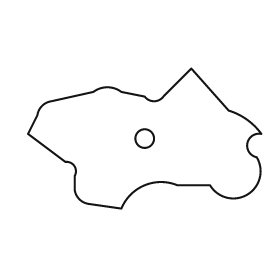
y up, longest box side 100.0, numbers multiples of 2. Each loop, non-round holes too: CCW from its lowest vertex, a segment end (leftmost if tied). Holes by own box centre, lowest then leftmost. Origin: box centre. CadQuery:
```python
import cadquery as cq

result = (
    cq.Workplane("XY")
    .moveTo(-10.0, -30.0)
    .threePointArc((0.0, -20.0), (14.0, -20.0))
    .lineTo(28.0, -20.0)
    .threePointArc((44.0, -24.0), (48.0, -8.0))
    .threePointArc((44.0, -2.0), (50.0, 2.0))
    .threePointArc((44.0, 8.0), (36.0, 12.0))
    .lineTo(20.0, 30.0)
    .lineTo(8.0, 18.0)
    .threePointArc((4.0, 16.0), (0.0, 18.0))
    .lineTo(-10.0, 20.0)
    .threePointArc((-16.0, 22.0), (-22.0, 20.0))
    .lineTo(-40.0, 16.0)
    .threePointArc((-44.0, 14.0), (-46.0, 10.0))
    .lineTo(-50.0, 2.0)
    .lineTo(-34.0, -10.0)
    .threePointArc((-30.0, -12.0), (-30.0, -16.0))
    .lineTo(-30.0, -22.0)
    .threePointArc((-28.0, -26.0), (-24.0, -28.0))
    .close()
    .moveTo(0.0, 0.0)
    .circle(4.0)
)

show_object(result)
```